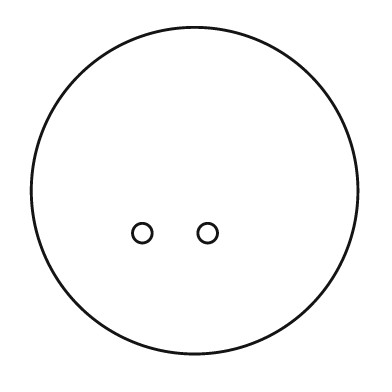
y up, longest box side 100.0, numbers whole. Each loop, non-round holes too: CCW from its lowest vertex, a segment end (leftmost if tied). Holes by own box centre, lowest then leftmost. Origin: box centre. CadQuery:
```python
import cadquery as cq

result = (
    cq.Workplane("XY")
    .moveTo(0.0, 0.0)
    .circle(50.0)
    .moveTo(-16.0, -13.0)
    .circle(3.0)
    .moveTo(4.0, -13.0)
    .circle(3.0)
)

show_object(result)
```